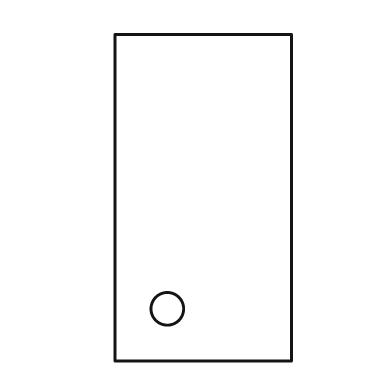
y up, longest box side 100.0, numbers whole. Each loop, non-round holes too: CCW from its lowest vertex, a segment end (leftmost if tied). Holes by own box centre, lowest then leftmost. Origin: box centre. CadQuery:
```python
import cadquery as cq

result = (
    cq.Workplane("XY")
    .moveTo(-27.0, -50.0)
    .lineTo(27.0, -50.0)
    .lineTo(27.0, 50.0)
    .lineTo(-27.0, 50.0)
    .close()
    .moveTo(-11.0, -34.0)
    .circle(5.0)
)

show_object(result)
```